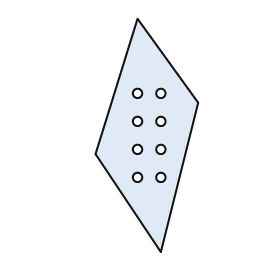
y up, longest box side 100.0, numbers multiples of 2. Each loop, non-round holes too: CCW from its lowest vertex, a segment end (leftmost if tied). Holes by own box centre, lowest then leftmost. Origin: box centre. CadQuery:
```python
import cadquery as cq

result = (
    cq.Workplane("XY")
    .moveTo(6.0, -50.0)
    .lineTo(22.0, 14.0)
    .lineTo(-4.0, 50.0)
    .lineTo(-22.0, -8.0)
    .close()
    .moveTo(-4.0, -18.0)
    .circle(2.0)
    .moveTo(6.0, -18.0)
    .circle(2.0)
    .moveTo(-4.0, -6.0)
    .circle(2.0)
    .moveTo(6.0, -6.0)
    .circle(2.0)
    .moveTo(-4.0, 6.0)
    .circle(2.0)
    .moveTo(6.0, 6.0)
    .circle(2.0)
    .moveTo(-4.0, 18.0)
    .circle(2.0)
    .moveTo(6.0, 18.0)
    .circle(2.0)
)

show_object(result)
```